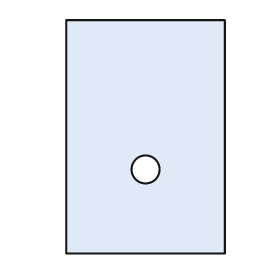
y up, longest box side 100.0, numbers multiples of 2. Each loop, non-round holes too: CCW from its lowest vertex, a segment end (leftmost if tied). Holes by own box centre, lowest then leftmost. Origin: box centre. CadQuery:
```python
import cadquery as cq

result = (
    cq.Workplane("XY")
    .moveTo(-34.0, -50.0)
    .lineTo(34.0, -50.0)
    .lineTo(34.0, 50.0)
    .lineTo(-34.0, 50.0)
    .close()
    .moveTo(0.0, -14.0)
    .circle(6.0)
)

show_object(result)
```